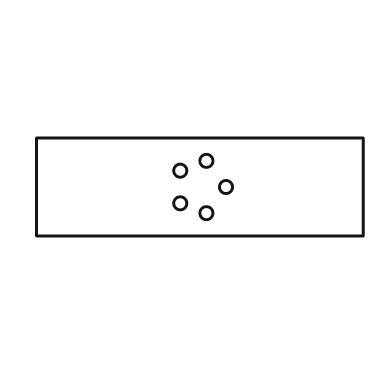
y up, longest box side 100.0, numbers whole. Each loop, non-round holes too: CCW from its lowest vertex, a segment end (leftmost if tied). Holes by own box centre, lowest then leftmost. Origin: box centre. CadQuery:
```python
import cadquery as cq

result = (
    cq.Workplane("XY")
    .moveTo(-50.0, -15.0)
    .lineTo(50.0, -15.0)
    .lineTo(50.0, 15.0)
    .lineTo(-50.0, 15.0)
    .close()
    .moveTo(2.0, -8.0)
    .circle(2.0)
    .moveTo(-6.0, -5.0)
    .circle(2.0)
    .moveTo(8.0, 0.0)
    .circle(2.0)
    .moveTo(-6.0, 5.0)
    .circle(2.0)
    .moveTo(2.0, 8.0)
    .circle(2.0)
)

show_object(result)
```